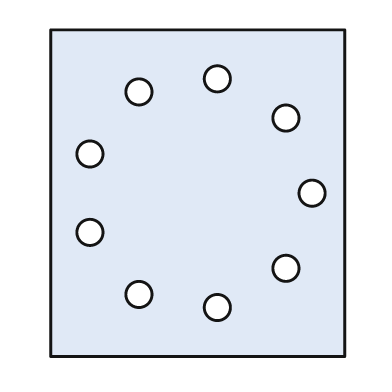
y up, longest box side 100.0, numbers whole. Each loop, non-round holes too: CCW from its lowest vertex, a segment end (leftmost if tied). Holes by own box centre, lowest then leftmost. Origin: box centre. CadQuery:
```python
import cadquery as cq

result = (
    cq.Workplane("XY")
    .moveTo(-45.0, -50.0)
    .lineTo(45.0, -50.0)
    .lineTo(45.0, 50.0)
    .lineTo(-45.0, 50.0)
    .close()
    .moveTo(6.0, -35.0)
    .circle(4.0)
    .moveTo(-18.0, -31.0)
    .circle(4.0)
    .moveTo(27.0, -23.0)
    .circle(4.0)
    .moveTo(-33.0, -12.0)
    .circle(4.0)
    .moveTo(35.0, 0.0)
    .circle(4.0)
    .moveTo(-33.0, 12.0)
    .circle(4.0)
    .moveTo(27.0, 23.0)
    .circle(4.0)
    .moveTo(-18.0, 31.0)
    .circle(4.0)
    .moveTo(6.0, 35.0)
    .circle(4.0)
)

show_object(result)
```